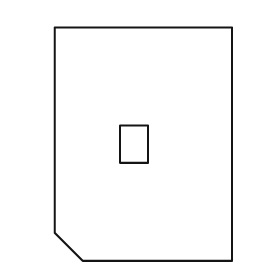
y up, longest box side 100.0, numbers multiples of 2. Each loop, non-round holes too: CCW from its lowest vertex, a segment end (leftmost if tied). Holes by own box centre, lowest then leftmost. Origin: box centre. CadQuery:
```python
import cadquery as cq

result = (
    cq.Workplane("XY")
    .moveTo(-26.0, -50.0)
    .lineTo(38.0, -50.0)
    .lineTo(38.0, 50.0)
    .lineTo(-38.0, 50.0)
    .lineTo(-38.0, -38.0)
    .close()
    .moveTo(-10.0, -8.0)
    .lineTo(2.0, -8.0)
    .lineTo(2.0, 8.0)
    .lineTo(-10.0, 8.0)
    .close()
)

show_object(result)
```